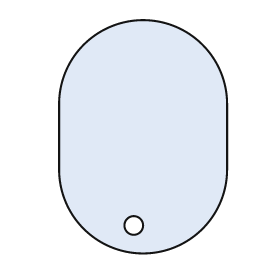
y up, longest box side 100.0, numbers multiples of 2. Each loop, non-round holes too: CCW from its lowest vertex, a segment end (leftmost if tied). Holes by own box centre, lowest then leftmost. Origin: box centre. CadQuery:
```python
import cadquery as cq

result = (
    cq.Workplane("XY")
    .moveTo(-36.0, -14.0)
    .threePointArc((0.0, -50.0), (36.0, -14.0))
    .lineTo(36.0, 14.0)
    .threePointArc((0.0, 50.0), (-36.0, 14.0))
    .close()
    .moveTo(-4.0, -38.0)
    .circle(4.0)
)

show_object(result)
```